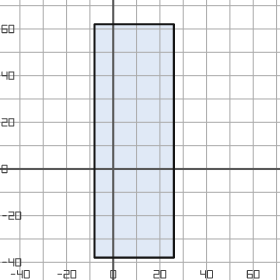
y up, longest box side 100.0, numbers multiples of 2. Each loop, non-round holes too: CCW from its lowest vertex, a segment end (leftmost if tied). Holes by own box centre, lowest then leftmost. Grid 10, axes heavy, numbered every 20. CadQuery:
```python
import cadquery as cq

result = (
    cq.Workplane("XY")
    .moveTo(-8.0, -38.0)
    .lineTo(26.0, -38.0)
    .lineTo(26.0, 62.0)
    .lineTo(-8.0, 62.0)
    .close()
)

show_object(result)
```